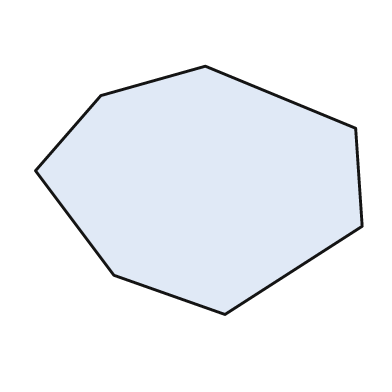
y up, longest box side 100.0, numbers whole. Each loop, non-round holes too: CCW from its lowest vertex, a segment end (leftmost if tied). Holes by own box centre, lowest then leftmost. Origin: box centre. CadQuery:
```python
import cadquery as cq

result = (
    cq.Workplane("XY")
    .moveTo(8.0, -38.0)
    .lineTo(50.0, -11.0)
    .lineTo(48.0, 19.0)
    .lineTo(2.0, 38.0)
    .lineTo(-30.0, 29.0)
    .lineTo(-50.0, 6.0)
    .lineTo(-26.0, -26.0)
    .close()
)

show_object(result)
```